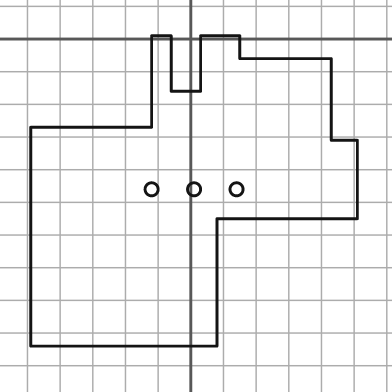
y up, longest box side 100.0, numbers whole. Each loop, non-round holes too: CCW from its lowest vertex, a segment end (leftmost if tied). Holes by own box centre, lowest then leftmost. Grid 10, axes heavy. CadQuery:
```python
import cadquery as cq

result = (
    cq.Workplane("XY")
    .moveTo(-49.0, -94.0)
    .lineTo(8.0, -94.0)
    .lineTo(8.0, -55.0)
    .lineTo(51.0, -55.0)
    .lineTo(51.0, -31.0)
    .lineTo(43.0, -31.0)
    .lineTo(43.0, -6.0)
    .lineTo(15.0, -6.0)
    .lineTo(15.0, 1.0)
    .lineTo(3.0, 1.0)
    .lineTo(3.0, -16.0)
    .lineTo(-6.0, -16.0)
    .lineTo(-6.0, 1.0)
    .lineTo(-12.0, 1.0)
    .lineTo(-12.0, -27.0)
    .lineTo(-49.0, -27.0)
    .close()
    .moveTo(-12.0, -46.0)
    .circle(2.0)
    .moveTo(1.0, -46.0)
    .circle(2.0)
    .moveTo(14.0, -46.0)
    .circle(2.0)
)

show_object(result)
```